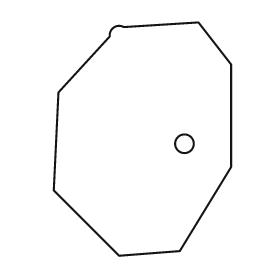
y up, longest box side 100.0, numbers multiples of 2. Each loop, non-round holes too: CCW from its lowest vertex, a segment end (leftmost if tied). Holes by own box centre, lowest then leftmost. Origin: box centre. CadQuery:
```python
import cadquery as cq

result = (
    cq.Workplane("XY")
    .moveTo(-10.0, -50.0)
    .lineTo(16.0, -48.0)
    .lineTo(38.0, -12.0)
    .lineTo(38.0, 32.0)
    .lineTo(24.0, 50.0)
    .lineTo(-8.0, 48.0)
    .threePointArc((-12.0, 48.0), (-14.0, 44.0))
    .lineTo(-36.0, 20.0)
    .lineTo(-38.0, -22.0)
    .close()
    .moveTo(18.0, -2.0)
    .circle(4.0)
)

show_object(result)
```